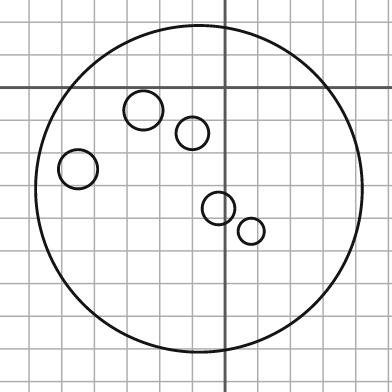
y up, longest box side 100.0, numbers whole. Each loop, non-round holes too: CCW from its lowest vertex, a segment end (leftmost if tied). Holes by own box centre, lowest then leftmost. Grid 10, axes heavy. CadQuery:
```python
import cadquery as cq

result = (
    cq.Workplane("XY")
    .moveTo(-8.0, -31.0)
    .circle(50.0)
    .moveTo(8.0, -44.0)
    .circle(4.0)
    .moveTo(-2.0, -37.0)
    .circle(5.0)
    .moveTo(-45.0, -25.0)
    .circle(6.0)
    .moveTo(-10.0, -14.0)
    .circle(5.0)
    .moveTo(-25.0, -7.0)
    .circle(6.0)
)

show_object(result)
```